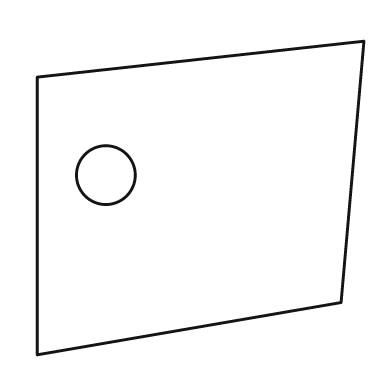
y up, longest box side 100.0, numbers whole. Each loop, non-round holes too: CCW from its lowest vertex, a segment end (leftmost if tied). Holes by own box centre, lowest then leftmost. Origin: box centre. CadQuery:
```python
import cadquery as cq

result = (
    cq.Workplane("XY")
    .moveTo(-50.0, -48.0)
    .lineTo(43.0, -32.0)
    .lineTo(50.0, 48.0)
    .lineTo(-50.0, 37.0)
    .close()
    .moveTo(-29.0, 7.0)
    .circle(9.0)
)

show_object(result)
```